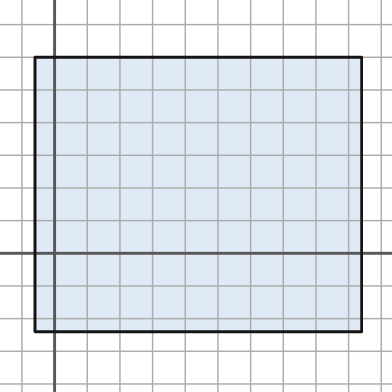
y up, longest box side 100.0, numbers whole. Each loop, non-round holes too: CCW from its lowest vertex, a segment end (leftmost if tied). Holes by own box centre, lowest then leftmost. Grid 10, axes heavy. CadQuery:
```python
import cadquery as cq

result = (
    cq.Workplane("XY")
    .moveTo(-6.0, -24.0)
    .lineTo(94.0, -24.0)
    .lineTo(94.0, 60.0)
    .lineTo(-6.0, 60.0)
    .close()
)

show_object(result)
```